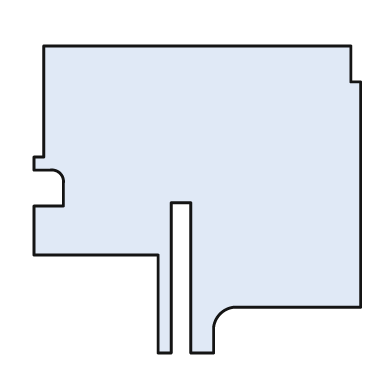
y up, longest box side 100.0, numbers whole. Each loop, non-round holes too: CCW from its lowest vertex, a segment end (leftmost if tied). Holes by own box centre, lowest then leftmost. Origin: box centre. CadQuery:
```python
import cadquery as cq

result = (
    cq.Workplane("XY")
    .moveTo(-12.0, -47.0)
    .lineTo(-8.0, -47.0)
    .lineTo(-8.0, -1.0)
    .lineTo(-2.0, -1.0)
    .lineTo(-2.0, -47.0)
    .lineTo(5.0, -47.0)
    .lineTo(5.0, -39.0)
    .threePointArc((7.0, -35.0), (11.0, -33.0))
    .lineTo(50.0, -33.0)
    .lineTo(50.0, 36.0)
    .lineTo(47.0, 36.0)
    .lineTo(47.0, 47.0)
    .lineTo(-47.0, 47.0)
    .lineTo(-47.0, 13.0)
    .lineTo(-50.0, 13.0)
    .lineTo(-50.0, 9.0)
    .lineTo(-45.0, 9.0)
    .threePointArc((-42.0, 8.0), (-41.0, 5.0))
    .lineTo(-41.0, -2.0)
    .lineTo(-50.0, -2.0)
    .lineTo(-50.0, -17.0)
    .lineTo(-12.0, -17.0)
    .close()
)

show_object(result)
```